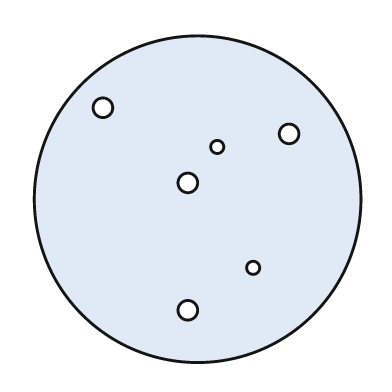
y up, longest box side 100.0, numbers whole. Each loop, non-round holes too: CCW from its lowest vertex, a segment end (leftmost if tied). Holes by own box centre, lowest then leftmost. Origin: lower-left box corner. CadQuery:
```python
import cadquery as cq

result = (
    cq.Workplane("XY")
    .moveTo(50.0, 50.0)
    .circle(50.0)
    .moveTo(47.0, 16.0)
    .circle(3.0)
    .moveTo(67.0, 29.0)
    .circle(2.0)
    .moveTo(47.0, 55.0)
    .circle(3.0)
    .moveTo(56.0, 66.0)
    .circle(2.0)
    .moveTo(78.0, 70.0)
    .circle(3.0)
    .moveTo(21.0, 78.0)
    .circle(3.0)
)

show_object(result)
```